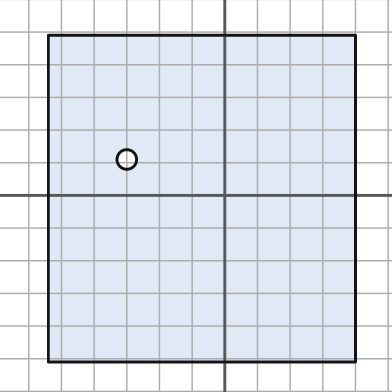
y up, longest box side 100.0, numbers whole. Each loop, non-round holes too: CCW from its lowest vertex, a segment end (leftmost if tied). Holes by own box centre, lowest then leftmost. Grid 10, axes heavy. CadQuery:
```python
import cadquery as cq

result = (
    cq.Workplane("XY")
    .moveTo(-54.0, -51.0)
    .lineTo(40.0, -51.0)
    .lineTo(40.0, 49.0)
    .lineTo(-54.0, 49.0)
    .close()
    .moveTo(-30.0, 11.0)
    .circle(3.0)
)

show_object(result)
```